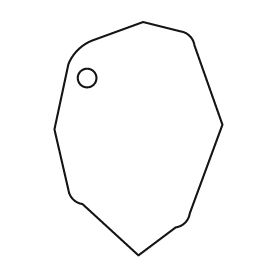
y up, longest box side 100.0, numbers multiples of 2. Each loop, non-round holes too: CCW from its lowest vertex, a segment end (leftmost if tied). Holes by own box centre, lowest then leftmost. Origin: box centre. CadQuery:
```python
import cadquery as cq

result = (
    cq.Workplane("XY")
    .moveTo(0.0, -50.0)
    .lineTo(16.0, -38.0)
    .threePointArc((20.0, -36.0), (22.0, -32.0))
    .lineTo(36.0, 6.0)
    .lineTo(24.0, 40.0)
    .threePointArc((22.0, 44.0), (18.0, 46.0))
    .lineTo(2.0, 50.0)
    .lineTo(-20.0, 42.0)
    .threePointArc((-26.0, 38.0), (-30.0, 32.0))
    .lineTo(-36.0, 4.0)
    .lineTo(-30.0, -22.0)
    .threePointArc((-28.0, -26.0), (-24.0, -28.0))
    .close()
    .moveTo(-22.0, 26.0)
    .circle(4.0)
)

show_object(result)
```